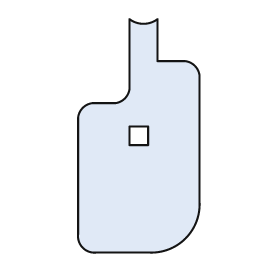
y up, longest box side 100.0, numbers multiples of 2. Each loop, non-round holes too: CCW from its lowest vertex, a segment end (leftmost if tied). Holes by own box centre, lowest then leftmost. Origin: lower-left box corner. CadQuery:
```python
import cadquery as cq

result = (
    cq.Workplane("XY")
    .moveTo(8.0, 0.0)
    .lineTo(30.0, 0.0)
    .threePointArc((46.0, 6.0), (52.0, 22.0))
    .lineTo(52.0, 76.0)
    .threePointArc((50.0, 80.0), (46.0, 82.0))
    .lineTo(34.0, 82.0)
    .lineTo(34.0, 100.0)
    .threePointArc((28.0, 98.0), (22.0, 100.0))
    .lineTo(22.0, 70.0)
    .threePointArc((20.0, 66.0), (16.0, 64.0))
    .lineTo(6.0, 64.0)
    .threePointArc((2.0, 62.0), (0.0, 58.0))
    .lineTo(0.0, 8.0)
    .threePointArc((2.0, 2.0), (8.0, 0.0))
    .close()
    .moveTo(22.0, 46.0)
    .lineTo(30.0, 46.0)
    .lineTo(30.0, 54.0)
    .lineTo(22.0, 54.0)
    .close()
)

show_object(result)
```